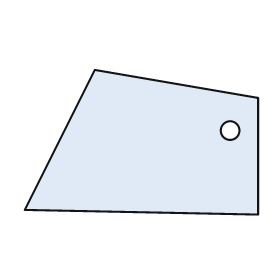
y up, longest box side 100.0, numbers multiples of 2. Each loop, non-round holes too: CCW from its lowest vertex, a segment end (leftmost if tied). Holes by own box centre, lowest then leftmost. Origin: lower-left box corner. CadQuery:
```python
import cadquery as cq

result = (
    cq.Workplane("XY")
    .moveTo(100.0, 0.0)
    .lineTo(100.0, 50.0)
    .lineTo(30.0, 62.0)
    .lineTo(0.0, 2.0)
    .close()
    .moveTo(88.0, 36.0)
    .circle(4.0)
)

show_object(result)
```